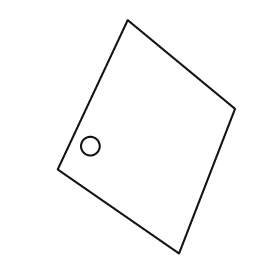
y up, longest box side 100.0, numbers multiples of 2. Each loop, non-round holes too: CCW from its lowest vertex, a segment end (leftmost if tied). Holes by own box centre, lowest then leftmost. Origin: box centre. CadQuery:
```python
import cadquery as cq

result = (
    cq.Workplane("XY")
    .moveTo(14.0, -50.0)
    .lineTo(38.0, 12.0)
    .lineTo(-8.0, 50.0)
    .lineTo(-38.0, -14.0)
    .close()
    .moveTo(-24.0, -4.0)
    .circle(4.0)
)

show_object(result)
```